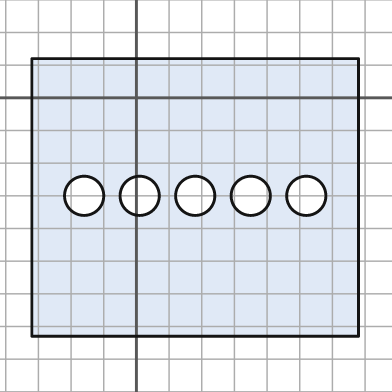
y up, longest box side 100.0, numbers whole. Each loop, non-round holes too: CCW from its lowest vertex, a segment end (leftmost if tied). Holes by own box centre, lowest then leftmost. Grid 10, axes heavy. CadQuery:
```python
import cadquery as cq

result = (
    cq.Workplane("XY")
    .moveTo(-32.0, -73.0)
    .lineTo(68.0, -73.0)
    .lineTo(68.0, 12.0)
    .lineTo(-32.0, 12.0)
    .close()
    .moveTo(-16.0, -30.0)
    .circle(6.0)
    .moveTo(1.0, -30.0)
    .circle(6.0)
    .moveTo(18.0, -30.0)
    .circle(6.0)
    .moveTo(35.0, -30.0)
    .circle(6.0)
    .moveTo(52.0, -30.0)
    .circle(6.0)
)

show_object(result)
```